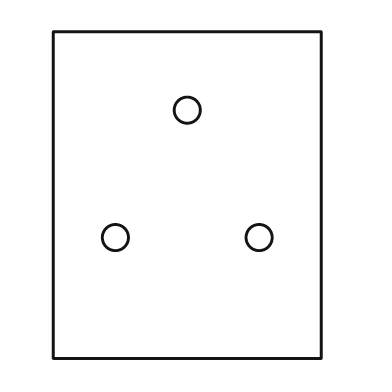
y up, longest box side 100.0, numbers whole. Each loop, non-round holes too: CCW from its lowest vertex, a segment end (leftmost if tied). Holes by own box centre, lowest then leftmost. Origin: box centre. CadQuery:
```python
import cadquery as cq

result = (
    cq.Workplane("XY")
    .moveTo(-41.0, -50.0)
    .lineTo(41.0, -50.0)
    .lineTo(41.0, 50.0)
    .lineTo(-41.0, 50.0)
    .close()
    .moveTo(-22.0, -13.0)
    .circle(4.0)
    .moveTo(22.0, -13.0)
    .circle(4.0)
    .moveTo(0.0, 26.0)
    .circle(4.0)
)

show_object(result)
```